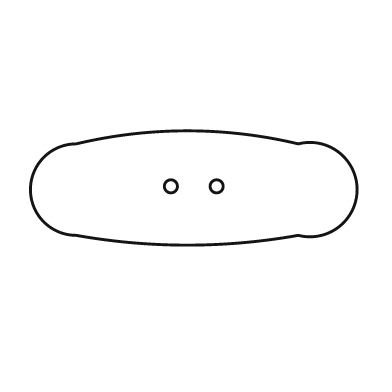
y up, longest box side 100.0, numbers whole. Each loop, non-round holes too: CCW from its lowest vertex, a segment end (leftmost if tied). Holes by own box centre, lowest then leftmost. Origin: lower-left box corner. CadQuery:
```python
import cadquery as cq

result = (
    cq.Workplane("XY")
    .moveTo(14.0, 3.0)
    .threePointArc((48.0, 0.0), (82.0, 3.0))
    .threePointArc((100.0, 17.0), (82.0, 31.0))
    .threePointArc((48.0, 35.0), (14.0, 31.0))
    .threePointArc((0.0, 17.0), (14.0, 3.0))
    .close()
    .moveTo(43.0, 18.0)
    .circle(2.0)
    .moveTo(57.0, 18.0)
    .circle(2.0)
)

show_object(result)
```